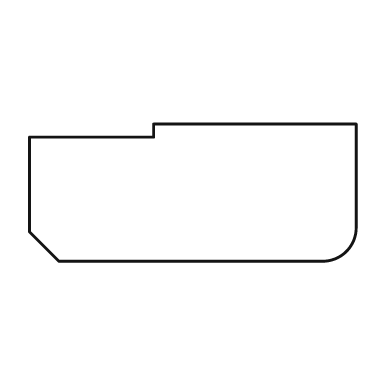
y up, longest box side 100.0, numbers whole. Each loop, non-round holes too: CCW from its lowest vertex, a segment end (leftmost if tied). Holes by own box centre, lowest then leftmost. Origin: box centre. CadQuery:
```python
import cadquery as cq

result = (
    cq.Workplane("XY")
    .moveTo(-41.0, -21.0)
    .lineTo(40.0, -21.0)
    .threePointArc((47.0, -18.0), (50.0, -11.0))
    .lineTo(50.0, 21.0)
    .lineTo(-12.0, 21.0)
    .lineTo(-12.0, 17.0)
    .lineTo(-50.0, 17.0)
    .lineTo(-50.0, -12.0)
    .close()
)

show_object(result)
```